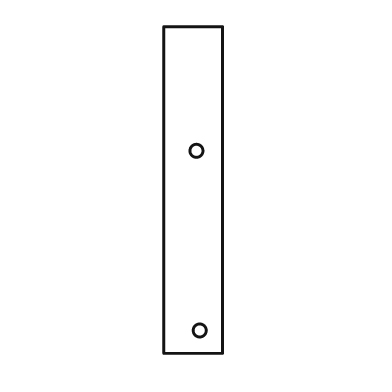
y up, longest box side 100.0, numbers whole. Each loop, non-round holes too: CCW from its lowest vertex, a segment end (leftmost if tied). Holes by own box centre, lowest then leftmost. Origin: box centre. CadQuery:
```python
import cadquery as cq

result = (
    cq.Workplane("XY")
    .moveTo(-9.0, -50.0)
    .lineTo(9.0, -50.0)
    .lineTo(9.0, 50.0)
    .lineTo(-9.0, 50.0)
    .close()
    .moveTo(2.0, -43.0)
    .circle(2.0)
    .moveTo(1.0, 12.0)
    .circle(2.0)
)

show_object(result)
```